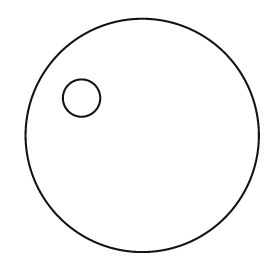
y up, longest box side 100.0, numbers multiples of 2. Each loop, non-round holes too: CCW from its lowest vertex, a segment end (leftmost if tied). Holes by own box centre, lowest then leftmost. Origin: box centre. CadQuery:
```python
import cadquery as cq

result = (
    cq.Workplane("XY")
    .moveTo(0.0, 0.0)
    .circle(50.0)
    .moveTo(-26.0, 16.0)
    .circle(8.0)
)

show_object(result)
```